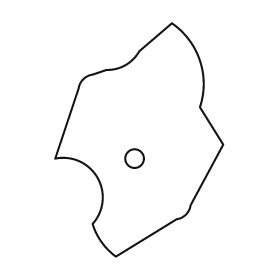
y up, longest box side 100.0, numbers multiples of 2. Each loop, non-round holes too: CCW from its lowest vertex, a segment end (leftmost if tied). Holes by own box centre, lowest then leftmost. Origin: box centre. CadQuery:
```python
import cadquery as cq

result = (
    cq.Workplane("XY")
    .moveTo(-10.0, -50.0)
    .lineTo(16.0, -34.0)
    .threePointArc((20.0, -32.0), (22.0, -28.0))
    .lineTo(36.0, -2.0)
    .lineTo(26.0, 14.0)
    .threePointArc((26.0, 34.0), (14.0, 50.0))
    .lineTo(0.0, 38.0)
    .threePointArc((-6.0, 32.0), (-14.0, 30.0))
    .lineTo(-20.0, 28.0)
    .threePointArc((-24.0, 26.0), (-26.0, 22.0))
    .lineTo(-36.0, -8.0)
    .threePointArc((-18.0, -16.0), (-20.0, -36.0))
    .threePointArc((-16.0, -44.0), (-10.0, -50.0))
    .close()
    .moveTo(-2.0, -8.0)
    .circle(4.0)
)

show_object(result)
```